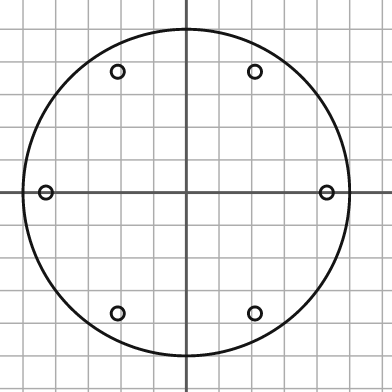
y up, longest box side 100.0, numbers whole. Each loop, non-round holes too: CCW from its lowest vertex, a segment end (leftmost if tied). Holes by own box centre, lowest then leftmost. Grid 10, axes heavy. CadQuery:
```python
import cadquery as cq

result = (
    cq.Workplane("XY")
    .moveTo(0.0, 0.0)
    .circle(50.0)
    .moveTo(-21.0, -37.0)
    .circle(2.0)
    .moveTo(21.0, -37.0)
    .circle(2.0)
    .moveTo(-43.0, 0.0)
    .circle(2.0)
    .moveTo(43.0, 0.0)
    .circle(2.0)
    .moveTo(-21.0, 37.0)
    .circle(2.0)
    .moveTo(21.0, 37.0)
    .circle(2.0)
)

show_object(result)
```